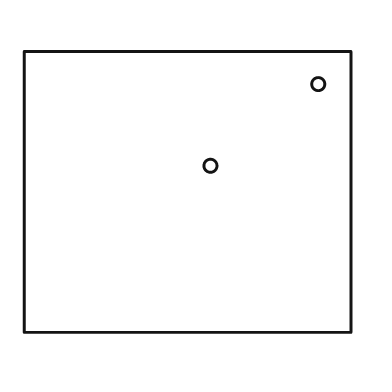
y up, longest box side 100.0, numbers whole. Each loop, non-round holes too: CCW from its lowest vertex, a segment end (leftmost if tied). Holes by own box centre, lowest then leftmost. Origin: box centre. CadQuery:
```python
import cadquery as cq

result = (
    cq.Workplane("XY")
    .moveTo(-50.0, -43.0)
    .lineTo(50.0, -43.0)
    .lineTo(50.0, 43.0)
    .lineTo(-50.0, 43.0)
    .close()
    .moveTo(7.0, 8.0)
    .circle(2.0)
    .moveTo(40.0, 33.0)
    .circle(2.0)
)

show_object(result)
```